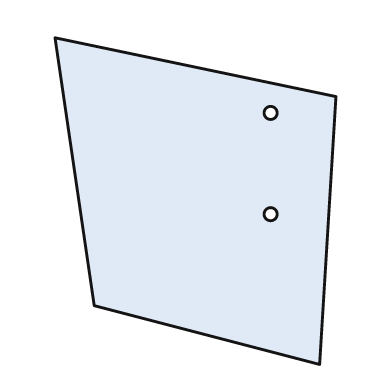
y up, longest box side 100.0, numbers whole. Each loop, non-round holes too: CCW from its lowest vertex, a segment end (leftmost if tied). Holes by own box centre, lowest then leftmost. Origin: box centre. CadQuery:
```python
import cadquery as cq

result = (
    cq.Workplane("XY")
    .moveTo(38.0, -50.0)
    .lineTo(43.0, 32.0)
    .lineTo(-43.0, 50.0)
    .lineTo(-31.0, -32.0)
    .close()
    .moveTo(23.0, -4.0)
    .circle(2.0)
    .moveTo(23.0, 27.0)
    .circle(2.0)
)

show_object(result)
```